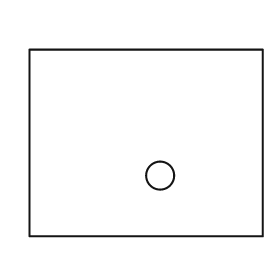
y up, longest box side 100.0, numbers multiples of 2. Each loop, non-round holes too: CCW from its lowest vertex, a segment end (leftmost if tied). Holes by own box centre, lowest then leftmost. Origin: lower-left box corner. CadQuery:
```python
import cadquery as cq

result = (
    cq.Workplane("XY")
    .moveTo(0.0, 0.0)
    .lineTo(100.0, 0.0)
    .lineTo(100.0, 80.0)
    .lineTo(0.0, 80.0)
    .close()
    .moveTo(56.0, 26.0)
    .circle(6.0)
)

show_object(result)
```